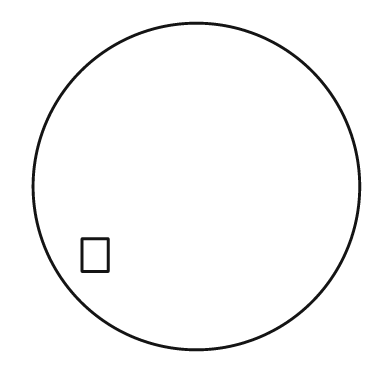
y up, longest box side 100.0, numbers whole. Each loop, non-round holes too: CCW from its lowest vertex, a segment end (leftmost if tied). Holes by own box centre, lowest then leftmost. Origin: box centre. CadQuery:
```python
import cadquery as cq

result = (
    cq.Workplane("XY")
    .moveTo(0.0, 0.0)
    .circle(50.0)
    .moveTo(-35.0, -26.0)
    .lineTo(-27.0, -26.0)
    .lineTo(-27.0, -16.0)
    .lineTo(-35.0, -16.0)
    .close()
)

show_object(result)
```